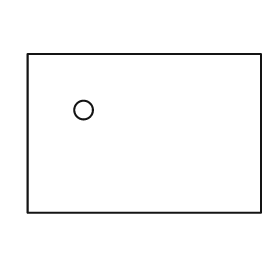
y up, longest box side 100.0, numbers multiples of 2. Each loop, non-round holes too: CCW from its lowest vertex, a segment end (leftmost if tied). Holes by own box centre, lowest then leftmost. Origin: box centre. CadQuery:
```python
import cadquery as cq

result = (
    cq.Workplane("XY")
    .moveTo(-50.0, -34.0)
    .lineTo(50.0, -34.0)
    .lineTo(50.0, 34.0)
    .lineTo(-50.0, 34.0)
    .close()
    .moveTo(-26.0, 10.0)
    .circle(4.0)
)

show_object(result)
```